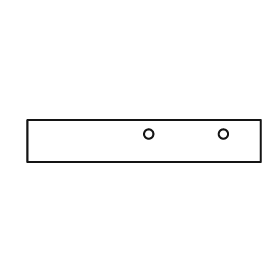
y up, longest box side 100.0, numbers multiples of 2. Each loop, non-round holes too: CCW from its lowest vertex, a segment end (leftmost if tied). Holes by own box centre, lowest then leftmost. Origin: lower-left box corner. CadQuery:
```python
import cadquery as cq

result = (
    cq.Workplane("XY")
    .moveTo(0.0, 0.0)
    .lineTo(100.0, 0.0)
    .lineTo(100.0, 18.0)
    .lineTo(0.0, 18.0)
    .close()
    .moveTo(52.0, 12.0)
    .circle(2.0)
    .moveTo(84.0, 12.0)
    .circle(2.0)
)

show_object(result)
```